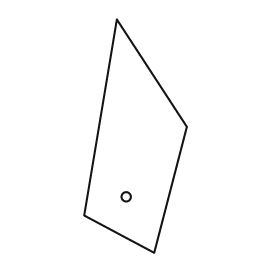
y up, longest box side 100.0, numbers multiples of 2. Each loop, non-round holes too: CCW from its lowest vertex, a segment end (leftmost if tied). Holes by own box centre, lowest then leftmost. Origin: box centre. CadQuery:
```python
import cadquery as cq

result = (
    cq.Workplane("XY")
    .moveTo(8.0, -50.0)
    .lineTo(22.0, 4.0)
    .lineTo(-8.0, 50.0)
    .lineTo(-22.0, -34.0)
    .close()
    .moveTo(-4.0, -26.0)
    .circle(2.0)
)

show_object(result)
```